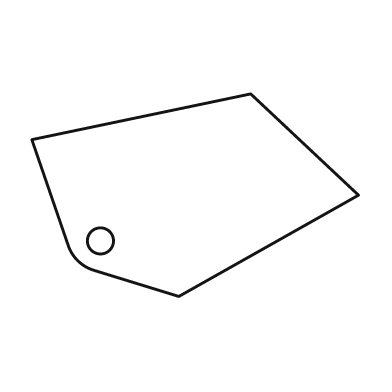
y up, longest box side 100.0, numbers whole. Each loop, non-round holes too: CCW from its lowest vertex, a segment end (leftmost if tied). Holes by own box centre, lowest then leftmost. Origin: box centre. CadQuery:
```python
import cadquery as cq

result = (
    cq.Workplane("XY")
    .moveTo(-5.0, -31.0)
    .lineTo(50.0, 0.0)
    .lineTo(17.0, 31.0)
    .lineTo(-50.0, 17.0)
    .lineTo(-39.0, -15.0)
    .threePointArc((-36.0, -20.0), (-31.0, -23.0))
    .close()
    .moveTo(-29.0, -14.0)
    .circle(4.0)
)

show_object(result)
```